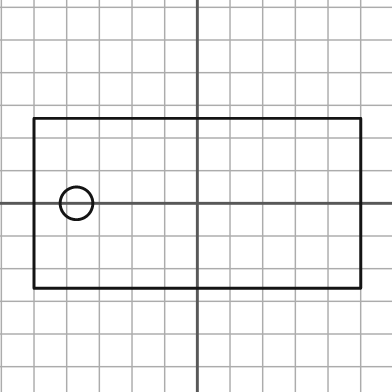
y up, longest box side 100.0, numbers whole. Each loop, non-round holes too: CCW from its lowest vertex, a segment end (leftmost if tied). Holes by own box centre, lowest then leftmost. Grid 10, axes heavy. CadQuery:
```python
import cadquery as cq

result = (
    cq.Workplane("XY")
    .moveTo(-50.0, -26.0)
    .lineTo(50.0, -26.0)
    .lineTo(50.0, 26.0)
    .lineTo(-50.0, 26.0)
    .close()
    .moveTo(-37.0, 0.0)
    .circle(5.0)
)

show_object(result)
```